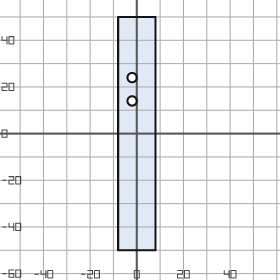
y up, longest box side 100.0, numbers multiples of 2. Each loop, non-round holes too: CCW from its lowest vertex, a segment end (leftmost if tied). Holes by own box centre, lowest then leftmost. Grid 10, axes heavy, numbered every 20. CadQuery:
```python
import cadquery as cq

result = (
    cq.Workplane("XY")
    .moveTo(-8.0, -50.0)
    .lineTo(8.0, -50.0)
    .lineTo(8.0, 50.0)
    .lineTo(-8.0, 50.0)
    .close()
    .moveTo(-2.0, 14.0)
    .circle(2.0)
    .moveTo(-2.0, 24.0)
    .circle(2.0)
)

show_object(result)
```